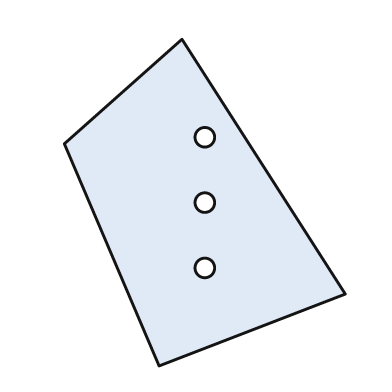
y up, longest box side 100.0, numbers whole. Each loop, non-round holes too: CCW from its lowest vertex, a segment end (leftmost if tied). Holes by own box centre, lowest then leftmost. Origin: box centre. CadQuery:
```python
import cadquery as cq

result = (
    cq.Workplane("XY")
    .moveTo(-14.0, -50.0)
    .lineTo(43.0, -28.0)
    .lineTo(-7.0, 50.0)
    .lineTo(-43.0, 18.0)
    .close()
    .moveTo(0.0, -20.0)
    .circle(3.0)
    .moveTo(0.0, 0.0)
    .circle(3.0)
    .moveTo(0.0, 20.0)
    .circle(3.0)
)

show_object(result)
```